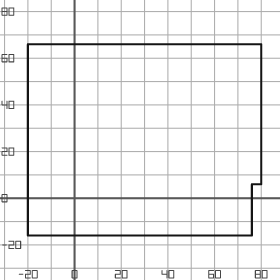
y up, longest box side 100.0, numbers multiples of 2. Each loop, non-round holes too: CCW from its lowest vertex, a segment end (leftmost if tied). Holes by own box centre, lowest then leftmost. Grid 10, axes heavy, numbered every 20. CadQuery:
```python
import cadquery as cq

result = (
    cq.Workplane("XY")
    .moveTo(-20.0, -16.0)
    .lineTo(76.0, -16.0)
    .lineTo(76.0, 6.0)
    .lineTo(80.0, 6.0)
    .lineTo(80.0, 66.0)
    .lineTo(-20.0, 66.0)
    .close()
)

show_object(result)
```